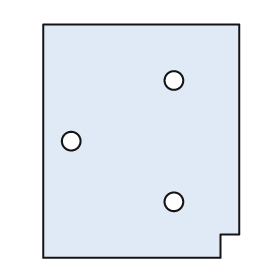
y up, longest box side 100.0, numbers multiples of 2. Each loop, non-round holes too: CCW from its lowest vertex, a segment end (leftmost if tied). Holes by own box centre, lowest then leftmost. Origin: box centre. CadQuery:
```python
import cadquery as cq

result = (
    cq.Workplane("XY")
    .moveTo(-42.0, -50.0)
    .lineTo(34.0, -50.0)
    .lineTo(34.0, -40.0)
    .lineTo(42.0, -40.0)
    .lineTo(42.0, 50.0)
    .lineTo(-42.0, 50.0)
    .close()
    .moveTo(14.0, -26.0)
    .circle(4.0)
    .moveTo(-30.0, 0.0)
    .circle(4.0)
    .moveTo(14.0, 26.0)
    .circle(4.0)
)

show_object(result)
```